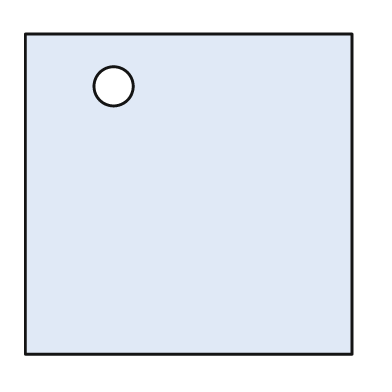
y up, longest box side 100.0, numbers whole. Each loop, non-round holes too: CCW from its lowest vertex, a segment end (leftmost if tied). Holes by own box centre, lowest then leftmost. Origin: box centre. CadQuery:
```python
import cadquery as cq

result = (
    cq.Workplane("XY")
    .moveTo(-50.0, -49.0)
    .lineTo(50.0, -49.0)
    .lineTo(50.0, 49.0)
    .lineTo(-50.0, 49.0)
    .close()
    .moveTo(-23.0, 33.0)
    .circle(6.0)
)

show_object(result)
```